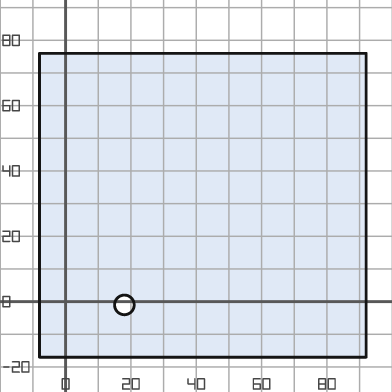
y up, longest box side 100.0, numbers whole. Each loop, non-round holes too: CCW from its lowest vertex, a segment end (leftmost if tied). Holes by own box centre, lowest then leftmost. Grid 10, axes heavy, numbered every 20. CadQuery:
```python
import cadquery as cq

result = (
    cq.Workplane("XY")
    .moveTo(-8.0, -17.0)
    .lineTo(92.0, -17.0)
    .lineTo(92.0, 76.0)
    .lineTo(-8.0, 76.0)
    .close()
    .moveTo(18.0, -1.0)
    .circle(3.0)
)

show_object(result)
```